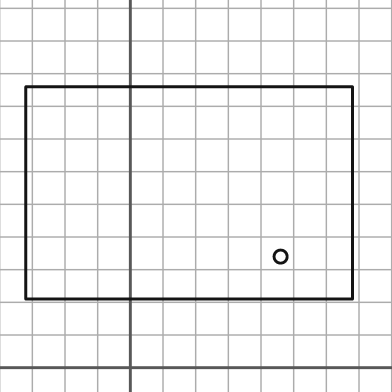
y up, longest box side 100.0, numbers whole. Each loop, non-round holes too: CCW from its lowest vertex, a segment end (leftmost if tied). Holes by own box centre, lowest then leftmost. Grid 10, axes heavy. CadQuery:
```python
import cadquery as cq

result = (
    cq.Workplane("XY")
    .moveTo(-32.0, 21.0)
    .lineTo(68.0, 21.0)
    .lineTo(68.0, 86.0)
    .lineTo(-32.0, 86.0)
    .close()
    .moveTo(46.0, 34.0)
    .circle(2.0)
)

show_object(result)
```